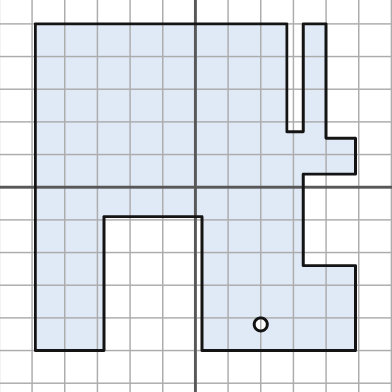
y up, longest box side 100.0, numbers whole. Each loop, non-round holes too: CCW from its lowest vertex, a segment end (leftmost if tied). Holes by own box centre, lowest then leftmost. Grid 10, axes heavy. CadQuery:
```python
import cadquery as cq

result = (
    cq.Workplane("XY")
    .moveTo(-49.0, -50.0)
    .lineTo(-28.0, -50.0)
    .lineTo(-28.0, -9.0)
    .lineTo(2.0, -9.0)
    .lineTo(2.0, -50.0)
    .lineTo(49.0, -50.0)
    .lineTo(49.0, -24.0)
    .lineTo(33.0, -24.0)
    .lineTo(33.0, 4.0)
    .lineTo(49.0, 4.0)
    .lineTo(49.0, 15.0)
    .lineTo(40.0, 15.0)
    .lineTo(40.0, 50.0)
    .lineTo(33.0, 50.0)
    .lineTo(33.0, 17.0)
    .lineTo(28.0, 17.0)
    .lineTo(28.0, 50.0)
    .lineTo(-49.0, 50.0)
    .close()
    .moveTo(20.0, -42.0)
    .circle(2.0)
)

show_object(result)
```